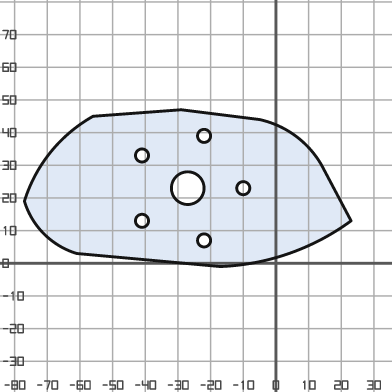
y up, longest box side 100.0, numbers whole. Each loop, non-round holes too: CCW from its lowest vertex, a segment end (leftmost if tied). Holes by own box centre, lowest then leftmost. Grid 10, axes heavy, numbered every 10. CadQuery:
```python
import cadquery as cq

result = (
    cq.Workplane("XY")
    .moveTo(-17.0, -1.0)
    .threePointArc((4.0, 3.0), (23.0, 13.0))
    .lineTo(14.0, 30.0)
    .threePointArc((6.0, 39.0), (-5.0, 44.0))
    .lineTo(-29.0, 47.0)
    .lineTo(-56.0, 45.0)
    .threePointArc((-69.0, 34.0), (-77.0, 19.0))
    .threePointArc((-71.0, 9.0), (-61.0, 3.0))
    .close()
    .moveTo(-22.0, 7.0)
    .circle(2.0)
    .moveTo(-41.0, 13.0)
    .circle(2.0)
    .moveTo(-27.0, 23.0)
    .circle(5.0)
    .moveTo(-10.0, 23.0)
    .circle(2.0)
    .moveTo(-41.0, 33.0)
    .circle(2.0)
    .moveTo(-22.0, 39.0)
    .circle(2.0)
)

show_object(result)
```